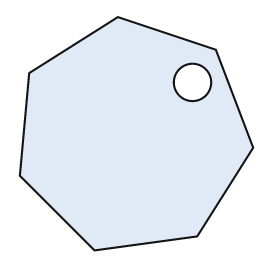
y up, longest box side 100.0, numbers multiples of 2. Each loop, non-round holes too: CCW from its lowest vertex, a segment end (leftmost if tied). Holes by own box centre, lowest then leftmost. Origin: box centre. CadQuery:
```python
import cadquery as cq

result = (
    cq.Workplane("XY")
    .moveTo(-18.0, -50.0)
    .lineTo(26.0, -44.0)
    .lineTo(50.0, -6.0)
    .lineTo(34.0, 36.0)
    .lineTo(-8.0, 50.0)
    .lineTo(-46.0, 26.0)
    .lineTo(-50.0, -18.0)
    .close()
    .moveTo(24.0, 22.0)
    .circle(8.0)
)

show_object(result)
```